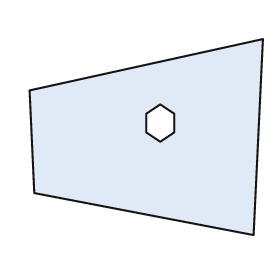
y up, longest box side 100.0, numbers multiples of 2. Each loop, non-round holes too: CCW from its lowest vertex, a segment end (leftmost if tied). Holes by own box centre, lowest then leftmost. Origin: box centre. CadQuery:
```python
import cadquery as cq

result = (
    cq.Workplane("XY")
    .moveTo(46.0, -42.0)
    .lineTo(50.0, 42.0)
    .lineTo(-50.0, 20.0)
    .lineTo(-48.0, -24.0)
    .close()
    .moveTo(6.0, -2.0)
    .lineTo(12.0, 2.0)
    .lineTo(12.0, 10.0)
    .lineTo(6.0, 14.0)
    .lineTo(0.0, 10.0)
    .lineTo(0.0, 2.0)
    .close()
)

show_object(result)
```